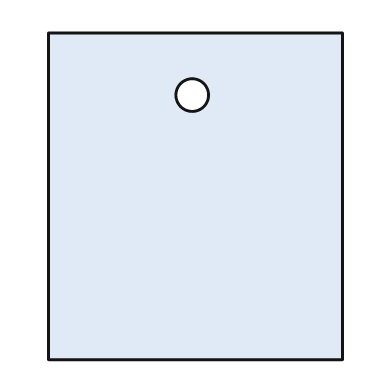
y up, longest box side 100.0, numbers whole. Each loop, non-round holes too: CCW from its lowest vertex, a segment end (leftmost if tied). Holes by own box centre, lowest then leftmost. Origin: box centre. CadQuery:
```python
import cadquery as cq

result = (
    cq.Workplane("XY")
    .moveTo(-45.0, -50.0)
    .lineTo(45.0, -50.0)
    .lineTo(45.0, 50.0)
    .lineTo(-45.0, 50.0)
    .close()
    .moveTo(-1.0, 31.0)
    .circle(5.0)
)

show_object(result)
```